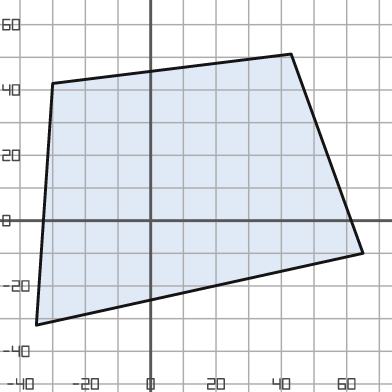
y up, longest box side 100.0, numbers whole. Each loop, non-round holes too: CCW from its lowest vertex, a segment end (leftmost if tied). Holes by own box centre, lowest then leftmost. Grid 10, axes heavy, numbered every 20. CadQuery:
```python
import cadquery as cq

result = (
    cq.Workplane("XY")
    .moveTo(-35.0, -32.0)
    .lineTo(65.0, -10.0)
    .lineTo(43.0, 51.0)
    .lineTo(-30.0, 42.0)
    .close()
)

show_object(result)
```